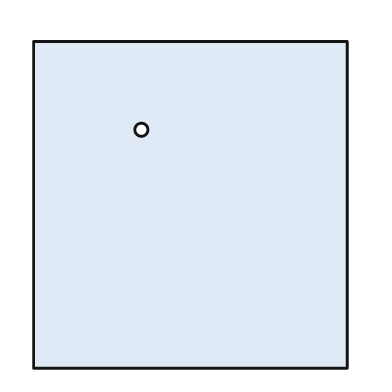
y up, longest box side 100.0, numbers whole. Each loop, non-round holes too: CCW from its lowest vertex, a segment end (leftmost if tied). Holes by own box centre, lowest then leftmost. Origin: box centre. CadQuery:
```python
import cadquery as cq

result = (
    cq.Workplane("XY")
    .moveTo(-48.0, -50.0)
    .lineTo(48.0, -50.0)
    .lineTo(48.0, 50.0)
    .lineTo(-48.0, 50.0)
    .close()
    .moveTo(-15.0, 23.0)
    .circle(2.0)
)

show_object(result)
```